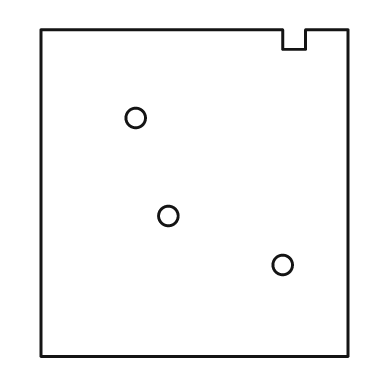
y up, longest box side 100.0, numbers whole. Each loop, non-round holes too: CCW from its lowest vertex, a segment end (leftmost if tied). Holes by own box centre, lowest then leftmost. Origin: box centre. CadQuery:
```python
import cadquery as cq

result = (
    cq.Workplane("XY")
    .moveTo(-47.0, -50.0)
    .lineTo(47.0, -50.0)
    .lineTo(47.0, 50.0)
    .lineTo(34.0, 50.0)
    .lineTo(34.0, 44.0)
    .lineTo(27.0, 44.0)
    .lineTo(27.0, 50.0)
    .lineTo(-47.0, 50.0)
    .close()
    .moveTo(27.0, -22.0)
    .circle(3.0)
    .moveTo(-8.0, -7.0)
    .circle(3.0)
    .moveTo(-18.0, 23.0)
    .circle(3.0)
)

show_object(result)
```